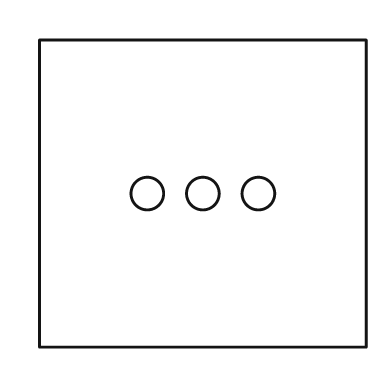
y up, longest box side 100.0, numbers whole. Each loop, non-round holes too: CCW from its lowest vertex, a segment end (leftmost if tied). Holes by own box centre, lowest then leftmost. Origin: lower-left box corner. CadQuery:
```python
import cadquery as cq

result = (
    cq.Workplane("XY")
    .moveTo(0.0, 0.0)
    .lineTo(100.0, 0.0)
    .lineTo(100.0, 94.0)
    .lineTo(0.0, 94.0)
    .close()
    .moveTo(33.0, 47.0)
    .circle(5.0)
    .moveTo(50.0, 47.0)
    .circle(5.0)
    .moveTo(67.0, 47.0)
    .circle(5.0)
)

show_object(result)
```